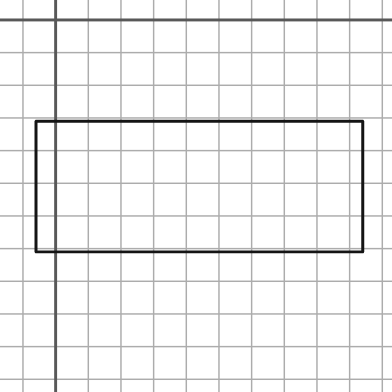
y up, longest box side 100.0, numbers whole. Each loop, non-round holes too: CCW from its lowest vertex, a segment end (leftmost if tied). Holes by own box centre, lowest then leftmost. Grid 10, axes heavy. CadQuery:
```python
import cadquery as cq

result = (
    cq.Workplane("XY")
    .moveTo(-6.0, -71.0)
    .lineTo(94.0, -71.0)
    .lineTo(94.0, -31.0)
    .lineTo(-6.0, -31.0)
    .close()
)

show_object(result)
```